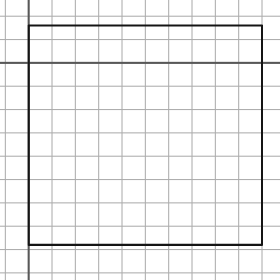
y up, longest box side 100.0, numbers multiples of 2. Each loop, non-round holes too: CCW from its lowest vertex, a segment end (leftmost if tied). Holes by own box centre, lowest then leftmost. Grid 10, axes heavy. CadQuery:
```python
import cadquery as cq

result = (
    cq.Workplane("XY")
    .moveTo(0.0, -78.0)
    .lineTo(100.0, -78.0)
    .lineTo(100.0, 16.0)
    .lineTo(0.0, 16.0)
    .close()
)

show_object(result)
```